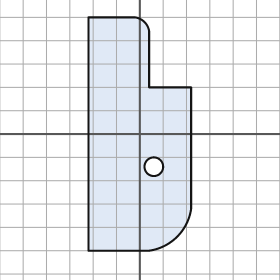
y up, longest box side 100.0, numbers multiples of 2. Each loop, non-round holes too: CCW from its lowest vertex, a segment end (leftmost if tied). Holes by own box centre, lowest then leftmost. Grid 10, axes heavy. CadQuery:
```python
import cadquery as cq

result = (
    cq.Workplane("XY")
    .moveTo(-22.0, -50.0)
    .lineTo(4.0, -50.0)
    .threePointArc((16.0, -44.0), (22.0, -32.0))
    .lineTo(22.0, 20.0)
    .lineTo(4.0, 20.0)
    .lineTo(4.0, 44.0)
    .threePointArc((2.0, 48.0), (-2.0, 50.0))
    .lineTo(-22.0, 50.0)
    .close()
    .moveTo(6.0, -14.0)
    .circle(4.0)
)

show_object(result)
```